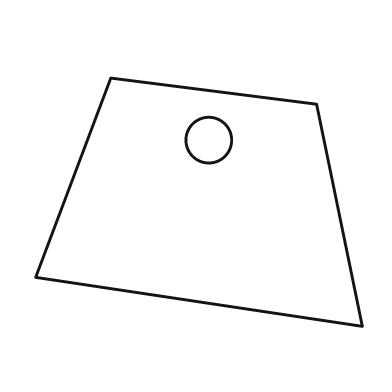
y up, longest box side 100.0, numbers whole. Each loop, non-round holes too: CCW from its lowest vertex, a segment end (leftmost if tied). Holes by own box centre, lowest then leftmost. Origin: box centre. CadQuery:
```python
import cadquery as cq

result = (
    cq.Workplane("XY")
    .moveTo(50.0, -38.0)
    .lineTo(36.0, 30.0)
    .lineTo(-27.0, 38.0)
    .lineTo(-50.0, -23.0)
    .close()
    .moveTo(3.0, 19.0)
    .circle(7.0)
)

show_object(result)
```